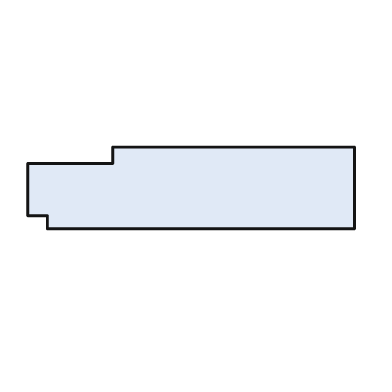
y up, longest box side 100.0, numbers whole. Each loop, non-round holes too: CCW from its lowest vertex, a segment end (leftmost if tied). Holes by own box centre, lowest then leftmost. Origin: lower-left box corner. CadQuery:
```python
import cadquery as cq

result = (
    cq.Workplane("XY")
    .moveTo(6.0, 0.0)
    .lineTo(100.0, 0.0)
    .lineTo(100.0, 25.0)
    .lineTo(26.0, 25.0)
    .lineTo(26.0, 20.0)
    .lineTo(0.0, 20.0)
    .lineTo(0.0, 4.0)
    .lineTo(6.0, 4.0)
    .close()
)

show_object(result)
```